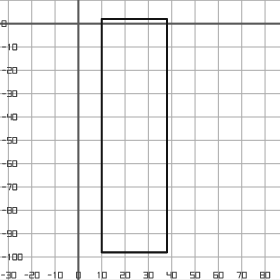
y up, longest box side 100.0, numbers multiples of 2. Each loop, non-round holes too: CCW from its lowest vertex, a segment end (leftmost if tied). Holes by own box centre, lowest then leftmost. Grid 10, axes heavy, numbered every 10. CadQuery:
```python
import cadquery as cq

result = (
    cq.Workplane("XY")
    .moveTo(10.0, -98.0)
    .lineTo(38.0, -98.0)
    .lineTo(38.0, 2.0)
    .lineTo(10.0, 2.0)
    .close()
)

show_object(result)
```